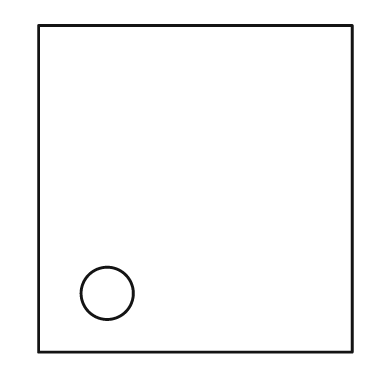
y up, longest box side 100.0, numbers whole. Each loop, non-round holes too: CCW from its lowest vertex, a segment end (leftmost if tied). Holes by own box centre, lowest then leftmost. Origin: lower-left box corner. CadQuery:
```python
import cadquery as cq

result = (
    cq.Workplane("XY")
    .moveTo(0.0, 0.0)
    .lineTo(96.0, 0.0)
    .lineTo(96.0, 100.0)
    .lineTo(0.0, 100.0)
    .close()
    .moveTo(21.0, 18.0)
    .circle(8.0)
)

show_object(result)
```